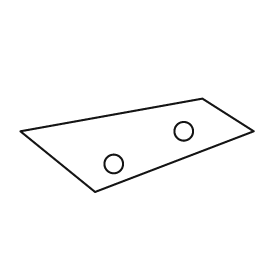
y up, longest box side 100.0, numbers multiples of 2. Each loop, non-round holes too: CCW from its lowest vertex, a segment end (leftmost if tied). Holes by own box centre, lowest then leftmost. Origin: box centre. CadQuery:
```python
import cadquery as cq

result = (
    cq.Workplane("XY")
    .moveTo(-18.0, -20.0)
    .lineTo(50.0, 6.0)
    .lineTo(28.0, 20.0)
    .lineTo(-50.0, 6.0)
    .close()
    .moveTo(-10.0, -8.0)
    .circle(4.0)
    .moveTo(20.0, 6.0)
    .circle(4.0)
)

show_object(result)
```